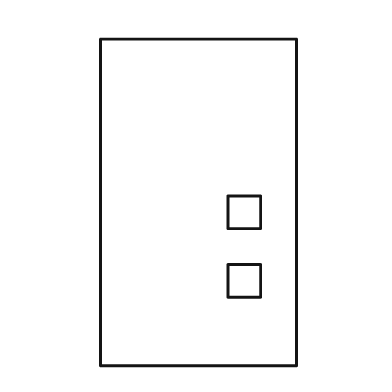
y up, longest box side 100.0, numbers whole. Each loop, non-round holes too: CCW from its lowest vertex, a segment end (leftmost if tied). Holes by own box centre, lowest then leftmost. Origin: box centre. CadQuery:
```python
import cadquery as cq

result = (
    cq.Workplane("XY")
    .moveTo(-30.0, -50.0)
    .lineTo(30.0, -50.0)
    .lineTo(30.0, 50.0)
    .lineTo(-30.0, 50.0)
    .close()
    .moveTo(9.0, -29.0)
    .lineTo(19.0, -29.0)
    .lineTo(19.0, -19.0)
    .lineTo(9.0, -19.0)
    .close()
    .moveTo(9.0, -8.0)
    .lineTo(19.0, -8.0)
    .lineTo(19.0, 2.0)
    .lineTo(9.0, 2.0)
    .close()
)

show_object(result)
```